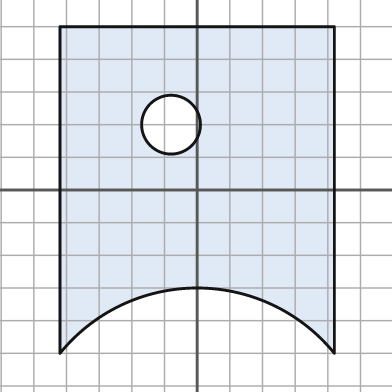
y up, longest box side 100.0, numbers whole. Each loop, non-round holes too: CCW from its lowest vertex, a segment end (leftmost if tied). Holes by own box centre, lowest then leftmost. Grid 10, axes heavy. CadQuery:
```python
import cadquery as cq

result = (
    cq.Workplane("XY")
    .moveTo(-42.0, -50.0)
    .threePointArc((0.0, -30.0), (42.0, -50.0))
    .lineTo(42.0, 50.0)
    .lineTo(-42.0, 50.0)
    .close()
    .moveTo(-8.0, 20.0)
    .circle(9.0)
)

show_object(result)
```